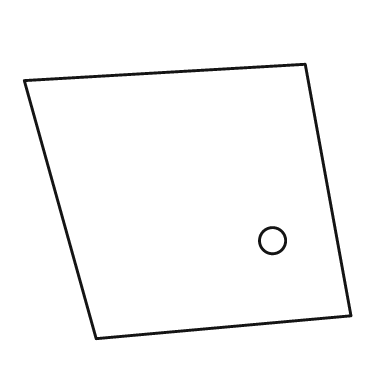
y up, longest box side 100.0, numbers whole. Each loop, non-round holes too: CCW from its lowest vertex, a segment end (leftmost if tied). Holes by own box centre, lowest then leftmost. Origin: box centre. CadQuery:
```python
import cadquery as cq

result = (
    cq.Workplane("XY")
    .moveTo(-28.0, -42.0)
    .lineTo(50.0, -35.0)
    .lineTo(36.0, 42.0)
    .lineTo(-50.0, 37.0)
    .close()
    .moveTo(26.0, -12.0)
    .circle(4.0)
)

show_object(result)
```